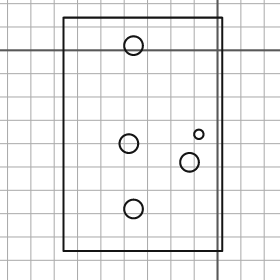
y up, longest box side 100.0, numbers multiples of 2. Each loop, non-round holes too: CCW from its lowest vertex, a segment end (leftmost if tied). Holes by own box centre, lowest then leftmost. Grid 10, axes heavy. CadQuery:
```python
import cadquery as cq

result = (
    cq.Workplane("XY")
    .moveTo(-66.0, -86.0)
    .lineTo(2.0, -86.0)
    .lineTo(2.0, 14.0)
    .lineTo(-66.0, 14.0)
    .close()
    .moveTo(-36.0, -68.0)
    .circle(4.0)
    .moveTo(-12.0, -48.0)
    .circle(4.0)
    .moveTo(-38.0, -40.0)
    .circle(4.0)
    .moveTo(-8.0, -36.0)
    .circle(2.0)
    .moveTo(-36.0, 2.0)
    .circle(4.0)
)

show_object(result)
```